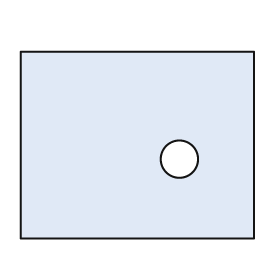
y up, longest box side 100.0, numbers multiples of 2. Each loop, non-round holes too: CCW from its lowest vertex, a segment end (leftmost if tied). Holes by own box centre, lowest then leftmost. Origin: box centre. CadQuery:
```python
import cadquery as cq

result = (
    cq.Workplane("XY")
    .moveTo(-50.0, -40.0)
    .lineTo(50.0, -40.0)
    .lineTo(50.0, 40.0)
    .lineTo(-50.0, 40.0)
    .close()
    .moveTo(18.0, -6.0)
    .circle(8.0)
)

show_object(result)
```